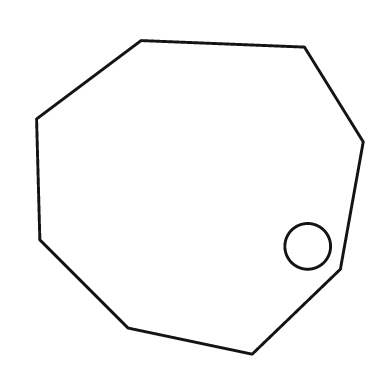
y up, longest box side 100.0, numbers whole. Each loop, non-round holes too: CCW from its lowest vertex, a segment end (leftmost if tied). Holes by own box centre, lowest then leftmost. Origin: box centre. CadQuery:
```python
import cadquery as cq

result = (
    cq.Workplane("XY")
    .moveTo(16.0, -48.0)
    .lineTo(43.0, -22.0)
    .lineTo(50.0, 17.0)
    .lineTo(32.0, 46.0)
    .lineTo(-18.0, 48.0)
    .lineTo(-50.0, 24.0)
    .lineTo(-49.0, -13.0)
    .lineTo(-22.0, -40.0)
    .close()
    .moveTo(33.0, -15.0)
    .circle(7.0)
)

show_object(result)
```